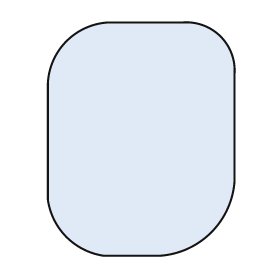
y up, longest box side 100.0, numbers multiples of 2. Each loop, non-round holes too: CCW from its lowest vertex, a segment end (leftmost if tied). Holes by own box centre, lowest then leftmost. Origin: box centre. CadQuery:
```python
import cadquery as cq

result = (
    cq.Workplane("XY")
    .moveTo(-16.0, -50.0)
    .lineTo(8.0, -50.0)
    .threePointArc((30.0, -40.0), (40.0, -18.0))
    .lineTo(40.0, 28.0)
    .threePointArc((34.0, 44.0), (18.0, 50.0))
    .lineTo(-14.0, 50.0)
    .threePointArc((-32.0, 42.0), (-40.0, 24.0))
    .lineTo(-40.0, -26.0)
    .threePointArc((-32.0, -42.0), (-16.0, -50.0))
    .close()
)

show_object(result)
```